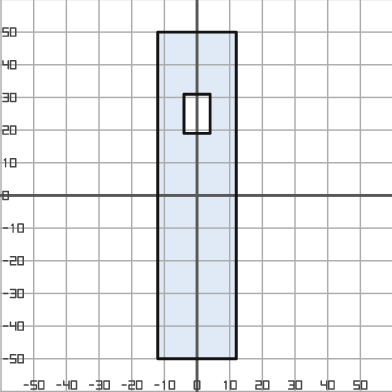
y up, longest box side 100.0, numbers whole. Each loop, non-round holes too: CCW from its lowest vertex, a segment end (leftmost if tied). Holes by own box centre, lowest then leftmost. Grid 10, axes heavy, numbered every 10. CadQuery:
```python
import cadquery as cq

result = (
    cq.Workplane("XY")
    .moveTo(-12.0, -50.0)
    .lineTo(12.0, -50.0)
    .lineTo(12.0, 50.0)
    .lineTo(-12.0, 50.0)
    .close()
    .moveTo(-4.0, 19.0)
    .lineTo(4.0, 19.0)
    .lineTo(4.0, 31.0)
    .lineTo(-4.0, 31.0)
    .close()
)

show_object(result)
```